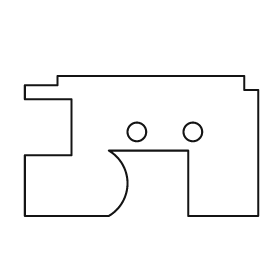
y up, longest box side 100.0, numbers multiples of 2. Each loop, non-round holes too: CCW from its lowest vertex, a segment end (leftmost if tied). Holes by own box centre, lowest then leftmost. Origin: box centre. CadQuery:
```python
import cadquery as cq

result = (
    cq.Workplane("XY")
    .moveTo(-50.0, -30.0)
    .lineTo(-14.0, -30.0)
    .threePointArc((-6.0, -16.0), (-14.0, -2.0))
    .lineTo(20.0, -2.0)
    .lineTo(20.0, -30.0)
    .lineTo(50.0, -30.0)
    .lineTo(50.0, 24.0)
    .lineTo(44.0, 24.0)
    .lineTo(44.0, 30.0)
    .lineTo(-36.0, 30.0)
    .lineTo(-36.0, 26.0)
    .lineTo(-50.0, 26.0)
    .lineTo(-50.0, 20.0)
    .lineTo(-30.0, 20.0)
    .lineTo(-30.0, -4.0)
    .lineTo(-50.0, -4.0)
    .close()
    .moveTo(-2.0, 6.0)
    .circle(4.0)
    .moveTo(22.0, 6.0)
    .circle(4.0)
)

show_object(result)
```